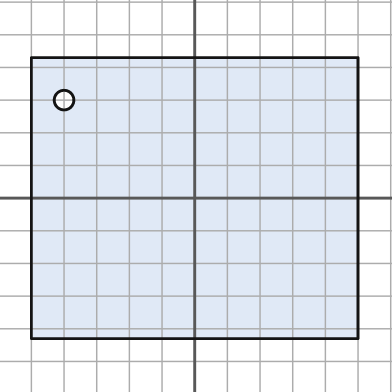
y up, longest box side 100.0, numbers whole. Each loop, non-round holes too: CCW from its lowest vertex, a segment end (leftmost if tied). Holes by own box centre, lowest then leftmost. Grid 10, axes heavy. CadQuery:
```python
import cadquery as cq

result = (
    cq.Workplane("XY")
    .moveTo(-50.0, -43.0)
    .lineTo(50.0, -43.0)
    .lineTo(50.0, 43.0)
    .lineTo(-50.0, 43.0)
    .close()
    .moveTo(-40.0, 30.0)
    .circle(3.0)
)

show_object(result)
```